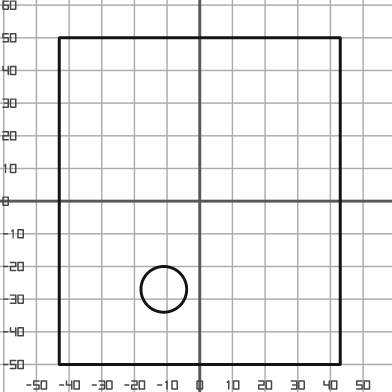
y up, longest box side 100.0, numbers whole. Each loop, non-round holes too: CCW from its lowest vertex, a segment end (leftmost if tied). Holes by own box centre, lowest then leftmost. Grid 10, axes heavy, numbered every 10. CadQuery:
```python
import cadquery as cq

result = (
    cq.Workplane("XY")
    .moveTo(-43.0, -50.0)
    .lineTo(43.0, -50.0)
    .lineTo(43.0, 50.0)
    .lineTo(-43.0, 50.0)
    .close()
    .moveTo(-11.0, -27.0)
    .circle(7.0)
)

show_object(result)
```